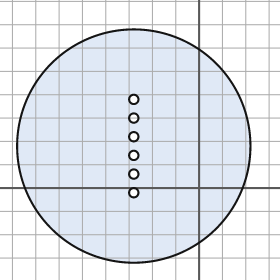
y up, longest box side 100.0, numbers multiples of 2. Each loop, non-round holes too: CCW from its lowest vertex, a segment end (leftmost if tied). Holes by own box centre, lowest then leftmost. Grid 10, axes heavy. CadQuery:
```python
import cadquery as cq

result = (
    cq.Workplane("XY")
    .moveTo(-28.0, 18.0)
    .circle(50.0)
    .moveTo(-28.0, -2.0)
    .circle(2.0)
    .moveTo(-28.0, 6.0)
    .circle(2.0)
    .moveTo(-28.0, 14.0)
    .circle(2.0)
    .moveTo(-28.0, 22.0)
    .circle(2.0)
    .moveTo(-28.0, 30.0)
    .circle(2.0)
    .moveTo(-28.0, 38.0)
    .circle(2.0)
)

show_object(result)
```